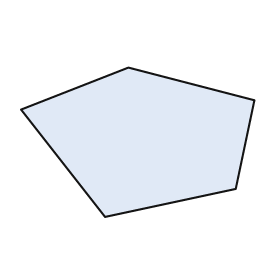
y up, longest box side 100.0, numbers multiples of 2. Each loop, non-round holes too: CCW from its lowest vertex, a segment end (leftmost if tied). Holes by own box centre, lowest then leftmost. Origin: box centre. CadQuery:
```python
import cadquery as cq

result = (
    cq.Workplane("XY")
    .moveTo(-14.0, -32.0)
    .lineTo(42.0, -20.0)
    .lineTo(50.0, 18.0)
    .lineTo(-4.0, 32.0)
    .lineTo(-50.0, 14.0)
    .close()
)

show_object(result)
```